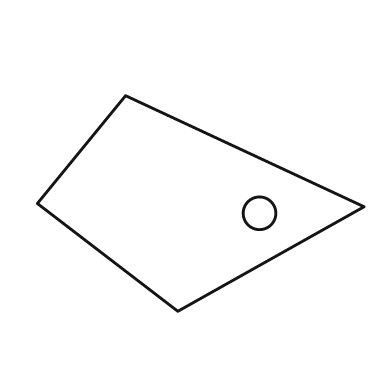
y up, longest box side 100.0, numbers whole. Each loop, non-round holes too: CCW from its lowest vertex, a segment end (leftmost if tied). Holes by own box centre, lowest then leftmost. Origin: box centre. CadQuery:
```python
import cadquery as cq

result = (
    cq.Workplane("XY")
    .moveTo(-7.0, -33.0)
    .lineTo(50.0, -1.0)
    .lineTo(-23.0, 33.0)
    .lineTo(-50.0, 0.0)
    .close()
    .moveTo(18.0, -3.0)
    .circle(5.0)
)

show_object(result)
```